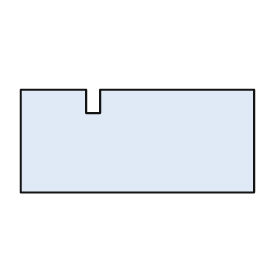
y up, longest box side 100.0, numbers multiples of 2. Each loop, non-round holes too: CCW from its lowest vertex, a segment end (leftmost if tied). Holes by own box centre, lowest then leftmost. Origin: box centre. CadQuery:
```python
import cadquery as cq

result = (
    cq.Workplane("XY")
    .moveTo(-50.0, -22.0)
    .lineTo(50.0, -22.0)
    .lineTo(50.0, 22.0)
    .lineTo(-16.0, 22.0)
    .lineTo(-16.0, 12.0)
    .lineTo(-22.0, 12.0)
    .lineTo(-22.0, 22.0)
    .lineTo(-50.0, 22.0)
    .close()
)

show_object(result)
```